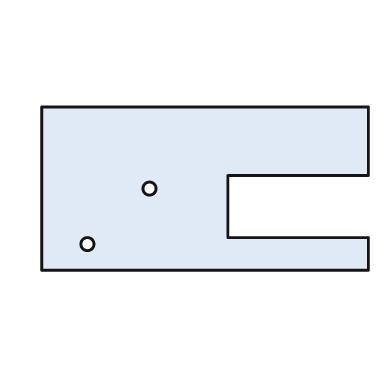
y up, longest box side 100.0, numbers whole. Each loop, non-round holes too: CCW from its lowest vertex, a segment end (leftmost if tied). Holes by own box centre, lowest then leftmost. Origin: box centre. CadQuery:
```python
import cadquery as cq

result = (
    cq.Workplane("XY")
    .moveTo(-50.0, -25.0)
    .lineTo(50.0, -25.0)
    .lineTo(50.0, -15.0)
    .lineTo(7.0, -15.0)
    .lineTo(7.0, 4.0)
    .lineTo(50.0, 4.0)
    .lineTo(50.0, 25.0)
    .lineTo(-50.0, 25.0)
    .close()
    .moveTo(-36.0, -17.0)
    .circle(2.0)
    .moveTo(-17.0, 0.0)
    .circle(2.0)
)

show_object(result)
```